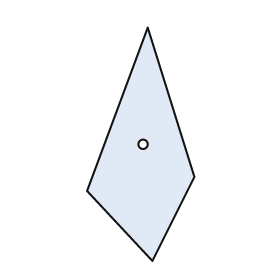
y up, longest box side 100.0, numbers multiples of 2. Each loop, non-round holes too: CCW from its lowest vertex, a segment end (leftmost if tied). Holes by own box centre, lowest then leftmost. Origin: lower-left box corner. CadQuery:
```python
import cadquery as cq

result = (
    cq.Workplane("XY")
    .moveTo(28.0, 0.0)
    .lineTo(46.0, 36.0)
    .lineTo(26.0, 100.0)
    .lineTo(0.0, 30.0)
    .close()
    .moveTo(24.0, 50.0)
    .circle(2.0)
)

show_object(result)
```